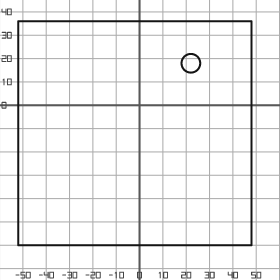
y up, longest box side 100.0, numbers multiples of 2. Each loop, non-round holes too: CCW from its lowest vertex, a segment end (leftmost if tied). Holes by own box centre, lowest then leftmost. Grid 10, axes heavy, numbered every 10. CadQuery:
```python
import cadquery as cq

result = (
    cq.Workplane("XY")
    .moveTo(-52.0, -60.0)
    .lineTo(48.0, -60.0)
    .lineTo(48.0, 36.0)
    .lineTo(-52.0, 36.0)
    .close()
    .moveTo(22.0, 18.0)
    .circle(4.0)
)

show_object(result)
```